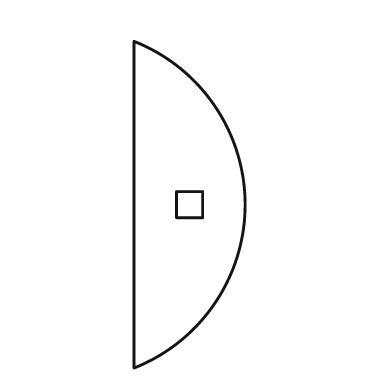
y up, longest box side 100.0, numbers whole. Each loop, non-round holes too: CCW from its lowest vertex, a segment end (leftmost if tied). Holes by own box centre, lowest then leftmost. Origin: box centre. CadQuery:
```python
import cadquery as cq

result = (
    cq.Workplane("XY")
    .moveTo(-17.0, -50.0)
    .threePointArc((17.0, 0.0), (-17.0, 50.0))
    .close()
    .moveTo(-4.0, -4.0)
    .lineTo(4.0, -4.0)
    .lineTo(4.0, 4.0)
    .lineTo(-4.0, 4.0)
    .close()
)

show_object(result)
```